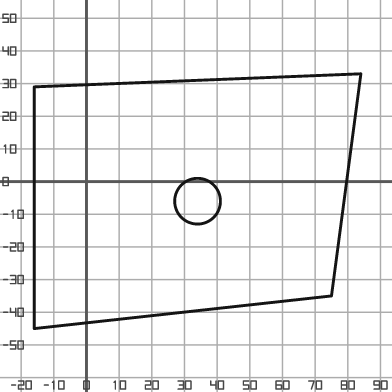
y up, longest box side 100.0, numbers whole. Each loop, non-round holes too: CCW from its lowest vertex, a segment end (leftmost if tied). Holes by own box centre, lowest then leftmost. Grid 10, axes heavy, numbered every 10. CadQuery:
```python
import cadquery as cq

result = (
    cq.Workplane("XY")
    .moveTo(-16.0, -45.0)
    .lineTo(75.0, -35.0)
    .lineTo(84.0, 33.0)
    .lineTo(-16.0, 29.0)
    .close()
    .moveTo(34.0, -6.0)
    .circle(7.0)
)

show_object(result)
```